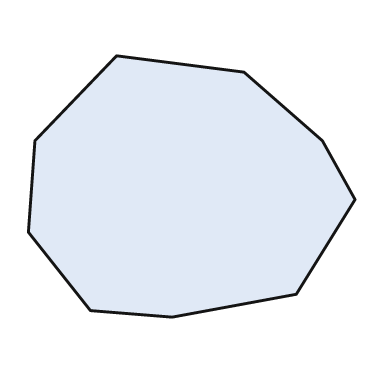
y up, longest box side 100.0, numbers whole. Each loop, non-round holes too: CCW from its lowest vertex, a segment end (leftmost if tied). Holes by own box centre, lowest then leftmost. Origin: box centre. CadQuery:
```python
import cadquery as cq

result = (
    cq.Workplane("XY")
    .moveTo(-6.0, -40.0)
    .lineTo(32.0, -33.0)
    .lineTo(50.0, -4.0)
    .lineTo(40.0, 14.0)
    .lineTo(16.0, 35.0)
    .lineTo(-23.0, 40.0)
    .lineTo(-48.0, 14.0)
    .lineTo(-50.0, -14.0)
    .lineTo(-31.0, -38.0)
    .close()
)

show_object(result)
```